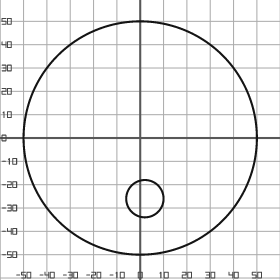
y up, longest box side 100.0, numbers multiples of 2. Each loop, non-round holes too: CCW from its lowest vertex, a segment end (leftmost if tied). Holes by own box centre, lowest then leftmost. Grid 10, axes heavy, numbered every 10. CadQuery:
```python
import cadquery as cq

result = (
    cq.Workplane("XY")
    .moveTo(0.0, 0.0)
    .circle(50.0)
    .moveTo(2.0, -26.0)
    .circle(8.0)
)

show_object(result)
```